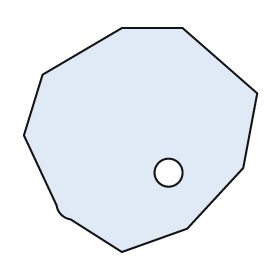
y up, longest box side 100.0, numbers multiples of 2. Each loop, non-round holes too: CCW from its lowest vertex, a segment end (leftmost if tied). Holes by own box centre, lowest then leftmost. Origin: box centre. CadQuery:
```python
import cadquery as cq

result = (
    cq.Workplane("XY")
    .moveTo(-8.0, -48.0)
    .lineTo(20.0, -38.0)
    .lineTo(44.0, -12.0)
    .lineTo(50.0, 20.0)
    .lineTo(18.0, 48.0)
    .lineTo(-8.0, 48.0)
    .lineTo(-42.0, 28.0)
    .lineTo(-50.0, 2.0)
    .lineTo(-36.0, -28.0)
    .threePointArc((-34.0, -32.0), (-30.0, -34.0))
    .close()
    .moveTo(12.0, -14.0)
    .circle(6.0)
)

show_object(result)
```